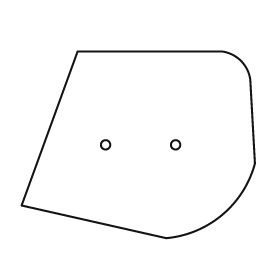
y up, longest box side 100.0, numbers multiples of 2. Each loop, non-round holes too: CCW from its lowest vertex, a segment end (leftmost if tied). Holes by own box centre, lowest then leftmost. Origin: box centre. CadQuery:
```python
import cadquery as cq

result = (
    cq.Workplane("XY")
    .moveTo(12.0, -40.0)
    .threePointArc((36.0, -30.0), (50.0, -8.0))
    .lineTo(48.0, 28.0)
    .threePointArc((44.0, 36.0), (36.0, 40.0))
    .lineTo(-26.0, 40.0)
    .lineTo(-50.0, -26.0)
    .close()
    .moveTo(-14.0, 0.0)
    .circle(2.0)
    .moveTo(16.0, 0.0)
    .circle(2.0)
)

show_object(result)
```